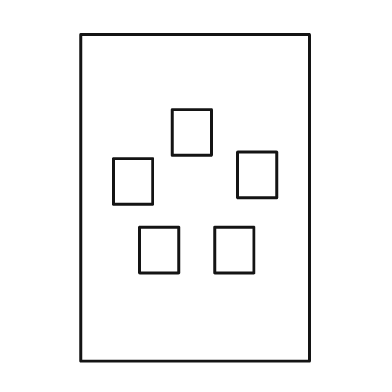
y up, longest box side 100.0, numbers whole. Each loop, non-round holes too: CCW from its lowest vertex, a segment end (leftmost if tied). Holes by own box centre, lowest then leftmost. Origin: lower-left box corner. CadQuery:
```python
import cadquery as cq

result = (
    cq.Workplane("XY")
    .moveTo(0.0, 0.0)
    .lineTo(70.0, 0.0)
    .lineTo(70.0, 100.0)
    .lineTo(0.0, 100.0)
    .close()
    .moveTo(18.0, 27.0)
    .lineTo(30.0, 27.0)
    .lineTo(30.0, 41.0)
    .lineTo(18.0, 41.0)
    .close()
    .moveTo(41.0, 27.0)
    .lineTo(53.0, 27.0)
    .lineTo(53.0, 41.0)
    .lineTo(41.0, 41.0)
    .close()
    .moveTo(10.0, 48.0)
    .lineTo(22.0, 48.0)
    .lineTo(22.0, 62.0)
    .lineTo(10.0, 62.0)
    .close()
    .moveTo(48.0, 50.0)
    .lineTo(60.0, 50.0)
    .lineTo(60.0, 64.0)
    .lineTo(48.0, 64.0)
    .close()
    .moveTo(28.0, 63.0)
    .lineTo(40.0, 63.0)
    .lineTo(40.0, 77.0)
    .lineTo(28.0, 77.0)
    .close()
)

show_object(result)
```